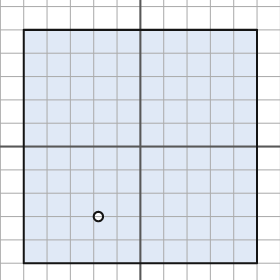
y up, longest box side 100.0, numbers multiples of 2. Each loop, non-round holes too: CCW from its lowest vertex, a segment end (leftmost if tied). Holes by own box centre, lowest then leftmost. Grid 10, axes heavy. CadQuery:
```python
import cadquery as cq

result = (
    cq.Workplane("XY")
    .moveTo(-50.0, -50.0)
    .lineTo(50.0, -50.0)
    .lineTo(50.0, 50.0)
    .lineTo(-50.0, 50.0)
    .close()
    .moveTo(-18.0, -30.0)
    .circle(2.0)
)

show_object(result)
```